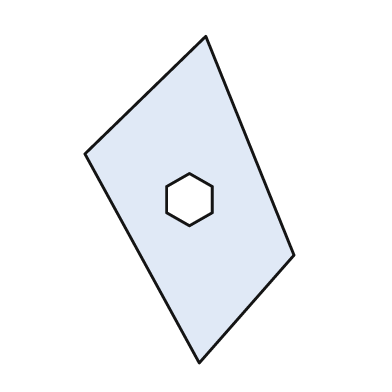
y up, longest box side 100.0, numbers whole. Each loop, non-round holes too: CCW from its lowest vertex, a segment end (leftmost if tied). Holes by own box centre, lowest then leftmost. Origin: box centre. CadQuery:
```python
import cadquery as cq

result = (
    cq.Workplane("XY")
    .moveTo(3.0, -50.0)
    .lineTo(32.0, -17.0)
    .lineTo(5.0, 50.0)
    .lineTo(-32.0, 14.0)
    .close()
    .moveTo(0.0, -8.0)
    .lineTo(7.0, -4.0)
    .lineTo(7.0, 4.0)
    .lineTo(0.0, 8.0)
    .lineTo(-7.0, 4.0)
    .lineTo(-7.0, -4.0)
    .close()
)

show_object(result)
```